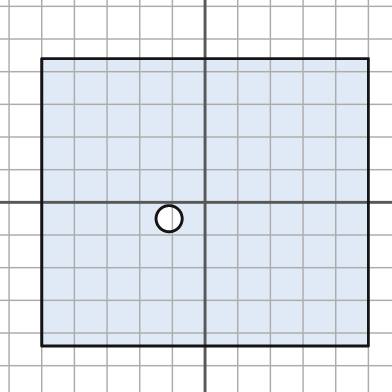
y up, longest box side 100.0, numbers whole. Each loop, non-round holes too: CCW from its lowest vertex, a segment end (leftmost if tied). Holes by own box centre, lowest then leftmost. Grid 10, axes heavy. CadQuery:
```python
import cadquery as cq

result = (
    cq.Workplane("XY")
    .moveTo(-50.0, -44.0)
    .lineTo(50.0, -44.0)
    .lineTo(50.0, 44.0)
    .lineTo(-50.0, 44.0)
    .close()
    .moveTo(-11.0, -5.0)
    .circle(4.0)
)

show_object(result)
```